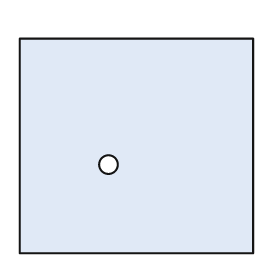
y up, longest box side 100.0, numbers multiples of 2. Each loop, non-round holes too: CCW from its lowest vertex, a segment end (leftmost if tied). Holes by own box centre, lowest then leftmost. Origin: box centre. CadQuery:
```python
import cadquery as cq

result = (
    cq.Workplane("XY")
    .moveTo(-50.0, -46.0)
    .lineTo(50.0, -46.0)
    .lineTo(50.0, 46.0)
    .lineTo(-50.0, 46.0)
    .close()
    .moveTo(-12.0, -8.0)
    .circle(4.0)
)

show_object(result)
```